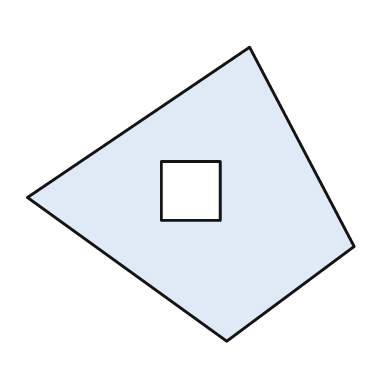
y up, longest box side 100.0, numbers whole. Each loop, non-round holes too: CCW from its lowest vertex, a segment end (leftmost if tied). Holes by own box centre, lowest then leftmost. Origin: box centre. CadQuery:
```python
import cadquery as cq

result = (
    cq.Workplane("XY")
    .moveTo(11.0, -45.0)
    .lineTo(50.0, -16.0)
    .lineTo(18.0, 45.0)
    .lineTo(-50.0, -1.0)
    .close()
    .moveTo(-9.0, -8.0)
    .lineTo(9.0, -8.0)
    .lineTo(9.0, 10.0)
    .lineTo(-9.0, 10.0)
    .close()
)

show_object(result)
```